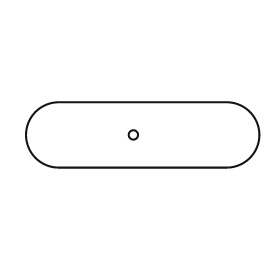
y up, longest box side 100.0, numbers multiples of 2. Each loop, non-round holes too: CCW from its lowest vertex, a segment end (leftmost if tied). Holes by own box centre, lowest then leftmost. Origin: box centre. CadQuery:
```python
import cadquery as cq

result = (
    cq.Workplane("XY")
    .moveTo(-36.0, -14.0)
    .lineTo(36.0, -14.0)
    .threePointArc((50.0, 0.0), (36.0, 14.0))
    .lineTo(-36.0, 14.0)
    .threePointArc((-50.0, 0.0), (-36.0, -14.0))
    .close()
    .moveTo(-4.0, 0.0)
    .circle(2.0)
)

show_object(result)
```